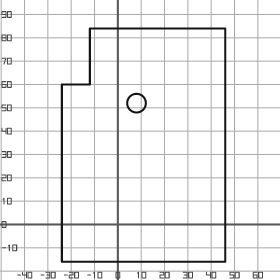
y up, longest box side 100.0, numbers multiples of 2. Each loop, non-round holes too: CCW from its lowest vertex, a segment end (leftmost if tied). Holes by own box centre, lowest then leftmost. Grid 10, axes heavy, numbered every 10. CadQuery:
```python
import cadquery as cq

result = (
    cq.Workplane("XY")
    .moveTo(-24.0, -16.0)
    .lineTo(46.0, -16.0)
    .lineTo(46.0, 84.0)
    .lineTo(-12.0, 84.0)
    .lineTo(-12.0, 60.0)
    .lineTo(-24.0, 60.0)
    .close()
    .moveTo(8.0, 52.0)
    .circle(4.0)
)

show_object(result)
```